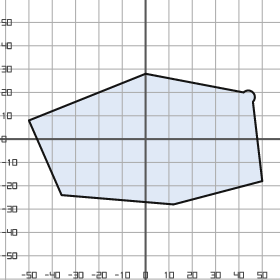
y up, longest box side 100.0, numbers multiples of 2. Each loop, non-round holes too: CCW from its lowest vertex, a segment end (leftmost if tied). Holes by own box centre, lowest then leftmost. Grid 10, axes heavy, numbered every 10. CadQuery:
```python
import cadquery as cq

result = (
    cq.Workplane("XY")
    .moveTo(12.0, -28.0)
    .lineTo(50.0, -18.0)
    .lineTo(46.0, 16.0)
    .threePointArc((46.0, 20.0), (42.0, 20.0))
    .lineTo(0.0, 28.0)
    .lineTo(-50.0, 8.0)
    .lineTo(-36.0, -24.0)
    .close()
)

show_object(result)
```